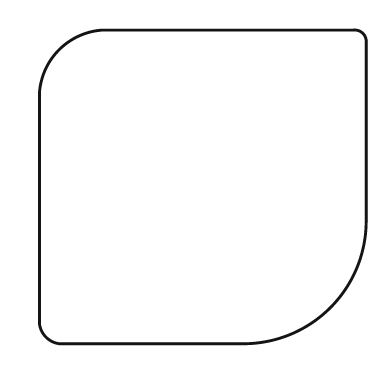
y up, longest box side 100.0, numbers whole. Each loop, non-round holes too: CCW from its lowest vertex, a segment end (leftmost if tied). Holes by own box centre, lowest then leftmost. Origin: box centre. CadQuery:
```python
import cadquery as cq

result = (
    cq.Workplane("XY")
    .moveTo(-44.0, -48.0)
    .lineTo(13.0, -48.0)
    .threePointArc((39.0, -37.0), (50.0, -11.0))
    .lineTo(50.0, 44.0)
    .threePointArc((49.0, 47.0), (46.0, 48.0))
    .lineTo(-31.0, 48.0)
    .threePointArc((-44.0, 42.0), (-50.0, 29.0))
    .lineTo(-50.0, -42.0)
    .threePointArc((-48.0, -46.0), (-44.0, -48.0))
    .close()
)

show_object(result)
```